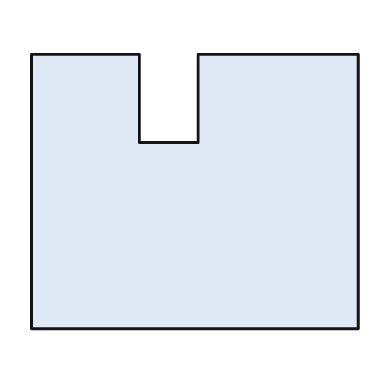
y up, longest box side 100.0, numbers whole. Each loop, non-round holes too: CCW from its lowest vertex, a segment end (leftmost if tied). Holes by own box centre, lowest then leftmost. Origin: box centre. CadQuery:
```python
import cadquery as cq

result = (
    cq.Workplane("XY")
    .moveTo(-50.0, -42.0)
    .lineTo(50.0, -42.0)
    .lineTo(50.0, 42.0)
    .lineTo(1.0, 42.0)
    .lineTo(1.0, 15.0)
    .lineTo(-17.0, 15.0)
    .lineTo(-17.0, 42.0)
    .lineTo(-50.0, 42.0)
    .close()
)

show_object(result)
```